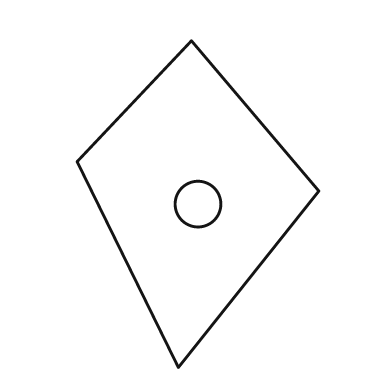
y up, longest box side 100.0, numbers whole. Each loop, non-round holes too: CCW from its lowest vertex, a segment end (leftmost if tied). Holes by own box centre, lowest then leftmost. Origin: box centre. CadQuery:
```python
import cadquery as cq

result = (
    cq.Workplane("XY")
    .moveTo(-6.0, -50.0)
    .lineTo(37.0, 4.0)
    .lineTo(-2.0, 50.0)
    .lineTo(-37.0, 13.0)
    .close()
    .moveTo(0.0, 0.0)
    .circle(7.0)
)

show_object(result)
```